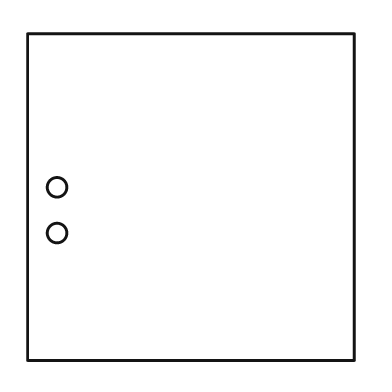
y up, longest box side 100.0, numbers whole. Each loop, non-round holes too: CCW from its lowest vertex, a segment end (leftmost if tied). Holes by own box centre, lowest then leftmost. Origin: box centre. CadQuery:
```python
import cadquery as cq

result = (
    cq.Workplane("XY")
    .moveTo(-50.0, -50.0)
    .lineTo(50.0, -50.0)
    .lineTo(50.0, 50.0)
    .lineTo(-50.0, 50.0)
    .close()
    .moveTo(-41.0, -11.0)
    .circle(3.0)
    .moveTo(-41.0, 3.0)
    .circle(3.0)
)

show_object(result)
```